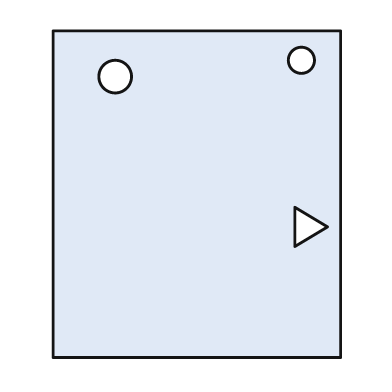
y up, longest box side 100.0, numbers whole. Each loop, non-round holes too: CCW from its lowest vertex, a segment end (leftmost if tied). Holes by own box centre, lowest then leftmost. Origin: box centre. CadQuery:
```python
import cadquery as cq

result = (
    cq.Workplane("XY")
    .moveTo(-44.0, -50.0)
    .lineTo(44.0, -50.0)
    .lineTo(44.0, 50.0)
    .lineTo(-44.0, 50.0)
    .close()
    .moveTo(30.0, -16.0)
    .lineTo(40.0, -10.0)
    .lineTo(30.0, -4.0)
    .close()
    .moveTo(-25.0, 36.0)
    .circle(5.0)
    .moveTo(32.0, 41.0)
    .circle(4.0)
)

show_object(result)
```